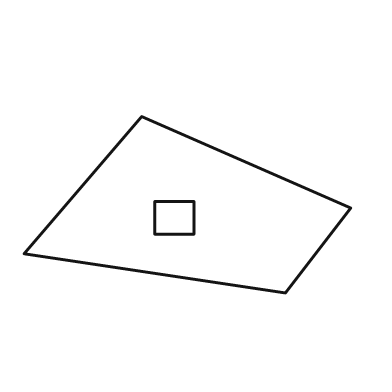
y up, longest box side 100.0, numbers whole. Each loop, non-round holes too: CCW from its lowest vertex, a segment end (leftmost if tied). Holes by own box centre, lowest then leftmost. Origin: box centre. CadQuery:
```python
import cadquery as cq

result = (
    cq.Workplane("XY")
    .moveTo(30.0, -27.0)
    .lineTo(50.0, -1.0)
    .lineTo(-14.0, 27.0)
    .lineTo(-50.0, -15.0)
    .close()
    .moveTo(-10.0, -9.0)
    .lineTo(2.0, -9.0)
    .lineTo(2.0, 1.0)
    .lineTo(-10.0, 1.0)
    .close()
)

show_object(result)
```